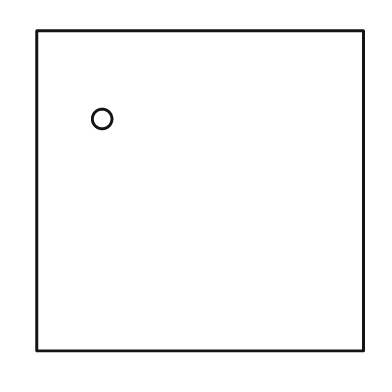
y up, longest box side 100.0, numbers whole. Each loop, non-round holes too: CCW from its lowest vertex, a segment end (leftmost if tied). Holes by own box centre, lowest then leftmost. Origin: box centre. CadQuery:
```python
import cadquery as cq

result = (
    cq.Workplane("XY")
    .moveTo(-50.0, -49.0)
    .lineTo(50.0, -49.0)
    .lineTo(50.0, 49.0)
    .lineTo(-50.0, 49.0)
    .close()
    .moveTo(-30.0, 22.0)
    .circle(3.0)
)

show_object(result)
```